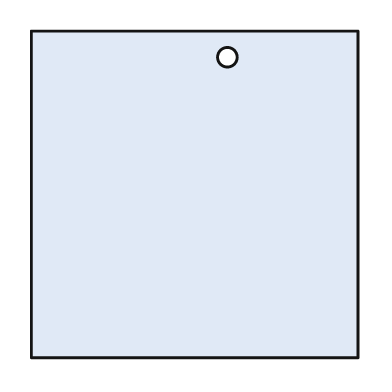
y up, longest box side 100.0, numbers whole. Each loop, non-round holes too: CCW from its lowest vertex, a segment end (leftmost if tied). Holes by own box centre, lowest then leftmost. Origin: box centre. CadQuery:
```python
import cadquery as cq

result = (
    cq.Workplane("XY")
    .moveTo(-50.0, -50.0)
    .lineTo(50.0, -50.0)
    .lineTo(50.0, 50.0)
    .lineTo(-50.0, 50.0)
    .close()
    .moveTo(10.0, 42.0)
    .circle(3.0)
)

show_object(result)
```